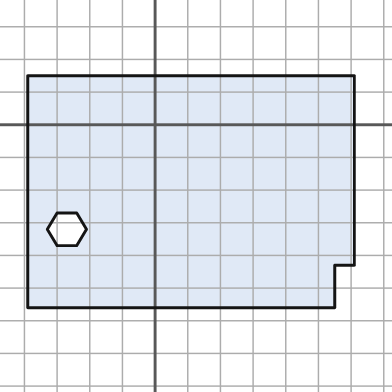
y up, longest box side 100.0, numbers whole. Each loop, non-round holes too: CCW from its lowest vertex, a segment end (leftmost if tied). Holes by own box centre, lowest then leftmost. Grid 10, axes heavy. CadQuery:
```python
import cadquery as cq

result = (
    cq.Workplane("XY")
    .moveTo(-39.0, -56.0)
    .lineTo(55.0, -56.0)
    .lineTo(55.0, -43.0)
    .lineTo(61.0, -43.0)
    .lineTo(61.0, 15.0)
    .lineTo(-39.0, 15.0)
    .close()
    .moveTo(-30.0, -37.0)
    .lineTo(-24.0, -37.0)
    .lineTo(-21.0, -32.0)
    .lineTo(-24.0, -27.0)
    .lineTo(-30.0, -27.0)
    .lineTo(-33.0, -32.0)
    .close()
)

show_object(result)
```